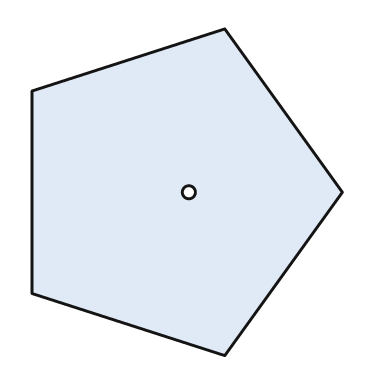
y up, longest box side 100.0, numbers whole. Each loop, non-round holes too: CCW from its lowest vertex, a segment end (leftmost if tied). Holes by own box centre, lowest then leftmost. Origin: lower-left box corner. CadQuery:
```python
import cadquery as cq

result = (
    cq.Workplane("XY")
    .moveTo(59.0, 0.0)
    .lineTo(95.0, 50.0)
    .lineTo(59.0, 100.0)
    .lineTo(0.0, 81.0)
    .lineTo(0.0, 19.0)
    .close()
    .moveTo(48.0, 50.0)
    .circle(2.0)
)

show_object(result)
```